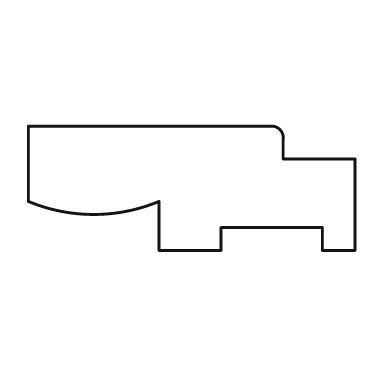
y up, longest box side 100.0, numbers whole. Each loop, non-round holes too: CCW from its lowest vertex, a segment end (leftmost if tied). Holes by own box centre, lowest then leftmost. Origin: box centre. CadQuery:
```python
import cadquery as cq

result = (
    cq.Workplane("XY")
    .moveTo(-10.0, -19.0)
    .lineTo(9.0, -19.0)
    .lineTo(9.0, -12.0)
    .lineTo(40.0, -12.0)
    .lineTo(40.0, -19.0)
    .lineTo(50.0, -19.0)
    .lineTo(50.0, 9.0)
    .lineTo(28.0, 9.0)
    .lineTo(28.0, 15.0)
    .threePointArc((27.0, 18.0), (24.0, 19.0))
    .lineTo(-50.0, 19.0)
    .lineTo(-50.0, -4.0)
    .threePointArc((-30.0, -8.0), (-10.0, -4.0))
    .close()
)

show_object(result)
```